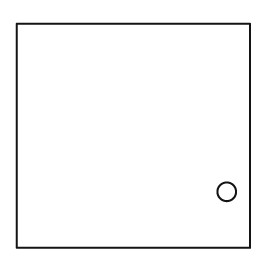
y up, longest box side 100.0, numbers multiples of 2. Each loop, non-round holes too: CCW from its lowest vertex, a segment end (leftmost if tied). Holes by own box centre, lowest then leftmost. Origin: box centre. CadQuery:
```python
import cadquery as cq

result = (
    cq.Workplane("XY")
    .moveTo(-50.0, -48.0)
    .lineTo(50.0, -48.0)
    .lineTo(50.0, 48.0)
    .lineTo(-50.0, 48.0)
    .close()
    .moveTo(40.0, -24.0)
    .circle(4.0)
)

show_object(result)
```